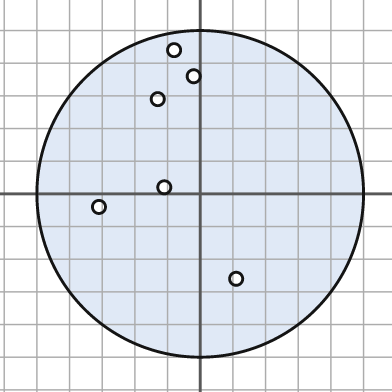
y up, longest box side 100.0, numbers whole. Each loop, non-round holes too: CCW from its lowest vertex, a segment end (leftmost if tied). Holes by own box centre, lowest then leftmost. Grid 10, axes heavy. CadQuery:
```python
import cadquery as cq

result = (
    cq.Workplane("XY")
    .moveTo(0.0, 0.0)
    .circle(50.0)
    .moveTo(11.0, -26.0)
    .circle(2.0)
    .moveTo(-31.0, -4.0)
    .circle(2.0)
    .moveTo(-11.0, 2.0)
    .circle(2.0)
    .moveTo(-13.0, 29.0)
    .circle(2.0)
    .moveTo(-2.0, 36.0)
    .circle(2.0)
    .moveTo(-8.0, 44.0)
    .circle(2.0)
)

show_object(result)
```